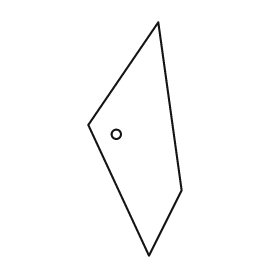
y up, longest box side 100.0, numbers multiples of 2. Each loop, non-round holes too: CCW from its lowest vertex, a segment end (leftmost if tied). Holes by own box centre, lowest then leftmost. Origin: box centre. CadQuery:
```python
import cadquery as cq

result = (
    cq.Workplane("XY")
    .moveTo(6.0, -50.0)
    .lineTo(20.0, -22.0)
    .lineTo(10.0, 50.0)
    .lineTo(-20.0, 6.0)
    .close()
    .moveTo(-8.0, 2.0)
    .circle(2.0)
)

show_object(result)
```